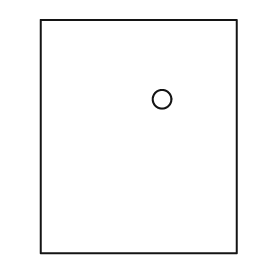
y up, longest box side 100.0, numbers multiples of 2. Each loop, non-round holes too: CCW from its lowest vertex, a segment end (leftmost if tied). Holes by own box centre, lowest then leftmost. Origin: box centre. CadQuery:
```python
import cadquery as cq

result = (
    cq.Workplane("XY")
    .moveTo(-42.0, -50.0)
    .lineTo(42.0, -50.0)
    .lineTo(42.0, 50.0)
    .lineTo(-42.0, 50.0)
    .close()
    .moveTo(10.0, 16.0)
    .circle(4.0)
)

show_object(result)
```